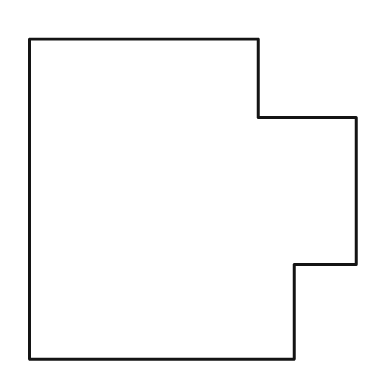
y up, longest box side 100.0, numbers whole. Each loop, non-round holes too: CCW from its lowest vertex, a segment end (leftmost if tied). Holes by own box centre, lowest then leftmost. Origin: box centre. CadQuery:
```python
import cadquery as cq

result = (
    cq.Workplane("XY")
    .moveTo(-50.0, -49.0)
    .lineTo(31.0, -49.0)
    .lineTo(31.0, -20.0)
    .lineTo(50.0, -20.0)
    .lineTo(50.0, 25.0)
    .lineTo(20.0, 25.0)
    .lineTo(20.0, 49.0)
    .lineTo(-50.0, 49.0)
    .close()
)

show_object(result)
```